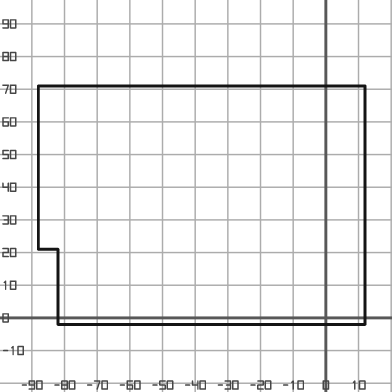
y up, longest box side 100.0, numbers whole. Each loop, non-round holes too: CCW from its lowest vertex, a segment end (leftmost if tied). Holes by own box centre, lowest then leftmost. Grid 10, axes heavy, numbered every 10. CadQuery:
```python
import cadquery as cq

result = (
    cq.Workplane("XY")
    .moveTo(-82.0, -2.0)
    .lineTo(12.0, -2.0)
    .lineTo(12.0, 71.0)
    .lineTo(-88.0, 71.0)
    .lineTo(-88.0, 21.0)
    .lineTo(-82.0, 21.0)
    .close()
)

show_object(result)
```